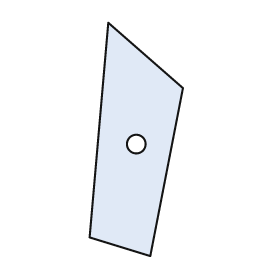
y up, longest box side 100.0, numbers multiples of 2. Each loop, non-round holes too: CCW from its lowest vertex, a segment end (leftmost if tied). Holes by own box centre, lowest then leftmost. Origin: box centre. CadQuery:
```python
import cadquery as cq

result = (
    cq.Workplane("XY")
    .moveTo(6.0, -50.0)
    .lineTo(20.0, 22.0)
    .lineTo(-12.0, 50.0)
    .lineTo(-20.0, -42.0)
    .close()
    .moveTo(0.0, -2.0)
    .circle(4.0)
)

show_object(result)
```